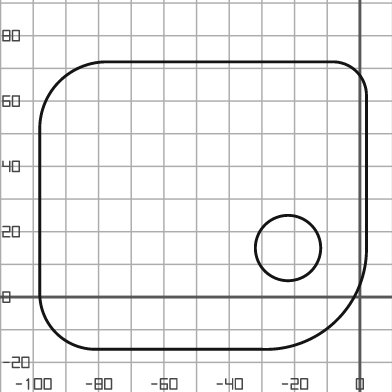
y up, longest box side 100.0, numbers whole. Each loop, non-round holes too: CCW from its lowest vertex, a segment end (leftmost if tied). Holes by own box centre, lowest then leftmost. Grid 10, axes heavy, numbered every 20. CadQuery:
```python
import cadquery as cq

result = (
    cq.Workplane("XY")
    .moveTo(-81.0, -16.0)
    .lineTo(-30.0, -16.0)
    .threePointArc((-7.0, -7.0), (2.0, 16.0))
    .lineTo(2.0, 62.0)
    .threePointArc((-1.0, 69.0), (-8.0, 72.0))
    .lineTo(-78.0, 72.0)
    .threePointArc((-92.0, 66.0), (-98.0, 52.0))
    .lineTo(-98.0, 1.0)
    .threePointArc((-93.0, -11.0), (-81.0, -16.0))
    .close()
    .moveTo(-22.0, 15.0)
    .circle(10.0)
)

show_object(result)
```